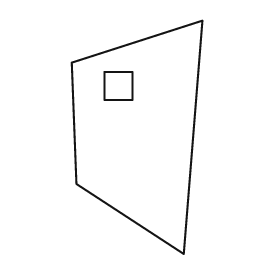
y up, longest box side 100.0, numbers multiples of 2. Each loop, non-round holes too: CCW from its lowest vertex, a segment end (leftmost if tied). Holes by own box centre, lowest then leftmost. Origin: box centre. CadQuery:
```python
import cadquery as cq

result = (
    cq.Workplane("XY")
    .moveTo(20.0, -50.0)
    .lineTo(28.0, 50.0)
    .lineTo(-28.0, 32.0)
    .lineTo(-26.0, -20.0)
    .close()
    .moveTo(-14.0, 16.0)
    .lineTo(-2.0, 16.0)
    .lineTo(-2.0, 28.0)
    .lineTo(-14.0, 28.0)
    .close()
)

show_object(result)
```